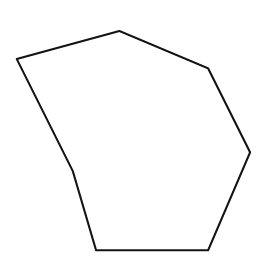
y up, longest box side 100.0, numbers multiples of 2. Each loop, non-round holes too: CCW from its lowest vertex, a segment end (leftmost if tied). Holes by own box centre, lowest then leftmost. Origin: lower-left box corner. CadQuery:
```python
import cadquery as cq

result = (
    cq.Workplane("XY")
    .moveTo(34.0, 0.0)
    .lineTo(82.0, 0.0)
    .lineTo(100.0, 42.0)
    .lineTo(82.0, 78.0)
    .lineTo(44.0, 94.0)
    .lineTo(0.0, 82.0)
    .lineTo(24.0, 34.0)
    .close()
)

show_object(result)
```